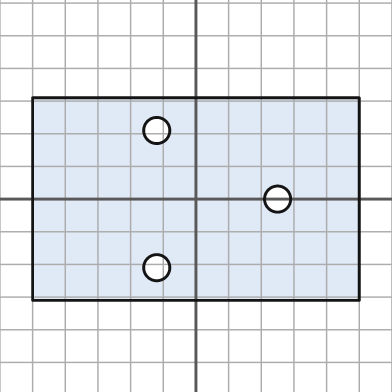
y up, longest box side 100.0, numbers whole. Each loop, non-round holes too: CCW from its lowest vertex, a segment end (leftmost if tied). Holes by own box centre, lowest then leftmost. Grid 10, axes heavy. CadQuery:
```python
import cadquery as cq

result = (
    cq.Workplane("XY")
    .moveTo(-50.0, -31.0)
    .lineTo(50.0, -31.0)
    .lineTo(50.0, 31.0)
    .lineTo(-50.0, 31.0)
    .close()
    .moveTo(-12.0, -21.0)
    .circle(4.0)
    .moveTo(25.0, 0.0)
    .circle(4.0)
    .moveTo(-12.0, 21.0)
    .circle(4.0)
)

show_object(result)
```